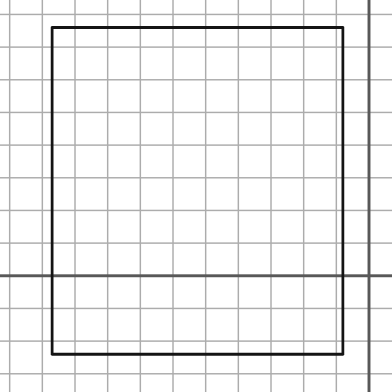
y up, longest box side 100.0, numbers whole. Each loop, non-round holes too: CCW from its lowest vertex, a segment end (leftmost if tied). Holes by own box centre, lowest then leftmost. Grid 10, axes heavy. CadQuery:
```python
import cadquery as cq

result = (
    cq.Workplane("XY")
    .moveTo(-97.0, -24.0)
    .lineTo(-8.0, -24.0)
    .lineTo(-8.0, 76.0)
    .lineTo(-97.0, 76.0)
    .close()
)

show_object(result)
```